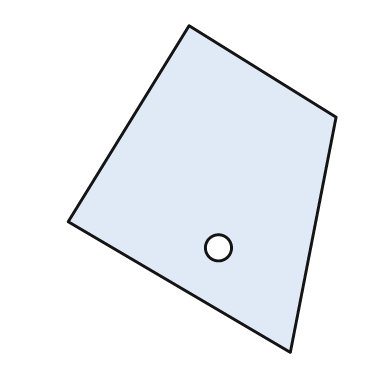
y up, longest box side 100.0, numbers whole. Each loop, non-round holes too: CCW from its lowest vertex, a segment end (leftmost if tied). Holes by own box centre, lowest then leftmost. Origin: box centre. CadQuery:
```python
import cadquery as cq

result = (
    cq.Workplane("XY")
    .moveTo(27.0, -50.0)
    .lineTo(41.0, 22.0)
    .lineTo(-4.0, 50.0)
    .lineTo(-41.0, -10.0)
    .close()
    .moveTo(5.0, -18.0)
    .circle(4.0)
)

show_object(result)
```